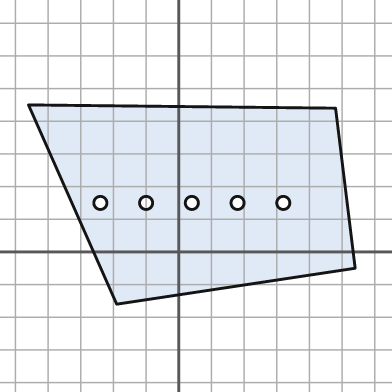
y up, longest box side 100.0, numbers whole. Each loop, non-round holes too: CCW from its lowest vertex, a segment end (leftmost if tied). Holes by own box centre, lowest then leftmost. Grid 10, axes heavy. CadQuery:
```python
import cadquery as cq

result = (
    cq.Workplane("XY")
    .moveTo(-19.0, -16.0)
    .lineTo(54.0, -5.0)
    .lineTo(48.0, 44.0)
    .lineTo(-46.0, 45.0)
    .close()
    .moveTo(-24.0, 15.0)
    .circle(2.0)
    .moveTo(-10.0, 15.0)
    .circle(2.0)
    .moveTo(4.0, 15.0)
    .circle(2.0)
    .moveTo(18.0, 15.0)
    .circle(2.0)
    .moveTo(32.0, 15.0)
    .circle(2.0)
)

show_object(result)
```